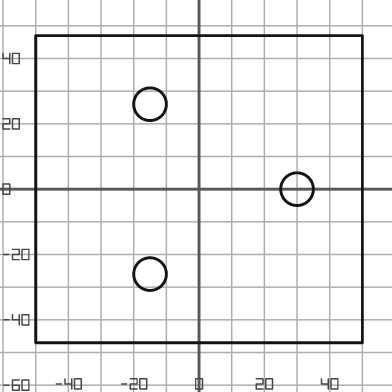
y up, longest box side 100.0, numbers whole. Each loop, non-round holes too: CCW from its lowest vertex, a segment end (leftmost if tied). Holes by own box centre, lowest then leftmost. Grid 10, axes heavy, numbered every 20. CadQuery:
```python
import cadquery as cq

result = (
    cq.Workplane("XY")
    .moveTo(-50.0, -47.0)
    .lineTo(50.0, -47.0)
    .lineTo(50.0, 47.0)
    .lineTo(-50.0, 47.0)
    .close()
    .moveTo(-15.0, -26.0)
    .circle(5.0)
    .moveTo(30.0, 0.0)
    .circle(5.0)
    .moveTo(-15.0, 26.0)
    .circle(5.0)
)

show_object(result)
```